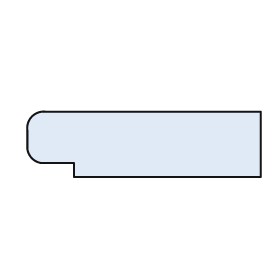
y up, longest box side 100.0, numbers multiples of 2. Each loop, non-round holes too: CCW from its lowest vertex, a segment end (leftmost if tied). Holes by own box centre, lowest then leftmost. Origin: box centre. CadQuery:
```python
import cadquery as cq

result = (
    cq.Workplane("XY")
    .moveTo(-30.0, -14.0)
    .lineTo(50.0, -14.0)
    .lineTo(50.0, 14.0)
    .lineTo(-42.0, 14.0)
    .threePointArc((-48.0, 12.0), (-50.0, 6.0))
    .lineTo(-50.0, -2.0)
    .threePointArc((-48.0, -6.0), (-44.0, -8.0))
    .lineTo(-30.0, -8.0)
    .close()
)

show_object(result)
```